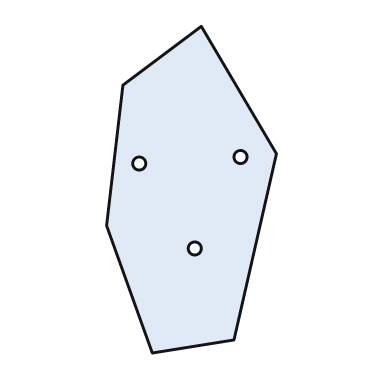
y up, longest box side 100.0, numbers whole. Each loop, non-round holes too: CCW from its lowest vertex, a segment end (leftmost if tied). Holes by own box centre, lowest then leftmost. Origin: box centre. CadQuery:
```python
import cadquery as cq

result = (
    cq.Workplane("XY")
    .moveTo(-12.0, -50.0)
    .lineTo(13.0, -46.0)
    .lineTo(26.0, 11.0)
    .lineTo(3.0, 50.0)
    .lineTo(-21.0, 32.0)
    .lineTo(-26.0, -11.0)
    .close()
    .moveTo(1.0, -18.0)
    .circle(2.0)
    .moveTo(-16.0, 8.0)
    .circle(2.0)
    .moveTo(15.0, 10.0)
    .circle(2.0)
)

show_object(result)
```